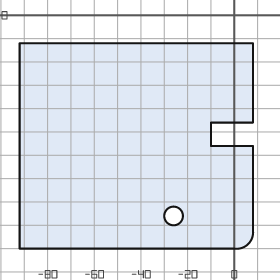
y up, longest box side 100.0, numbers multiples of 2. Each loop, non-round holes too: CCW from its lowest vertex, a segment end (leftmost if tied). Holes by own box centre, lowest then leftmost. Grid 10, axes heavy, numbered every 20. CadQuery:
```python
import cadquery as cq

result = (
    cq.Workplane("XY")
    .moveTo(-92.0, -100.0)
    .lineTo(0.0, -100.0)
    .threePointArc((6.0, -98.0), (8.0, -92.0))
    .lineTo(8.0, -56.0)
    .lineTo(-10.0, -56.0)
    .lineTo(-10.0, -46.0)
    .lineTo(8.0, -46.0)
    .lineTo(8.0, -12.0)
    .lineTo(-92.0, -12.0)
    .close()
    .moveTo(-26.0, -86.0)
    .circle(4.0)
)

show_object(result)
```